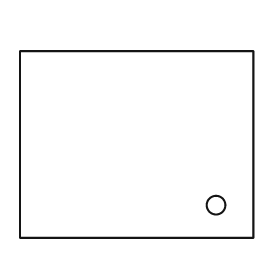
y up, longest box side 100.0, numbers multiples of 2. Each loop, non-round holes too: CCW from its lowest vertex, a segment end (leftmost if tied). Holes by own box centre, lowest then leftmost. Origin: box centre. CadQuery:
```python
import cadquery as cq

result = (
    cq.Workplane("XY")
    .moveTo(-50.0, -40.0)
    .lineTo(50.0, -40.0)
    .lineTo(50.0, 40.0)
    .lineTo(-50.0, 40.0)
    .close()
    .moveTo(34.0, -26.0)
    .circle(4.0)
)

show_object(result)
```